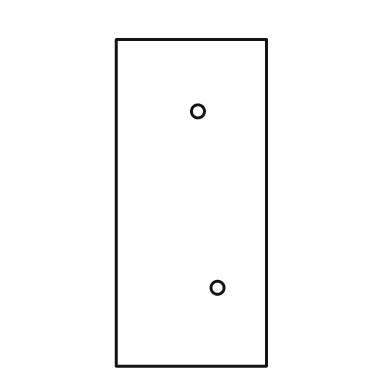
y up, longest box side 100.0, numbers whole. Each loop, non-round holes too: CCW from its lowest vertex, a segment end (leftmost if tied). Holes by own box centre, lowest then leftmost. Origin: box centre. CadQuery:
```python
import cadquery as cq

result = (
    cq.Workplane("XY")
    .moveTo(-23.0, -50.0)
    .lineTo(23.0, -50.0)
    .lineTo(23.0, 50.0)
    .lineTo(-23.0, 50.0)
    .close()
    .moveTo(8.0, -26.0)
    .circle(2.0)
    .moveTo(2.0, 28.0)
    .circle(2.0)
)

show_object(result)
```